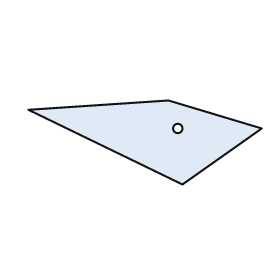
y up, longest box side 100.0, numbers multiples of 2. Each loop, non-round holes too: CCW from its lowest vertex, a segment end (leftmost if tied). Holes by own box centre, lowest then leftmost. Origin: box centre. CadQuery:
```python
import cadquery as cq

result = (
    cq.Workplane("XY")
    .moveTo(16.0, -18.0)
    .lineTo(50.0, 6.0)
    .lineTo(10.0, 18.0)
    .lineTo(-50.0, 14.0)
    .close()
    .moveTo(14.0, 6.0)
    .circle(2.0)
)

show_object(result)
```